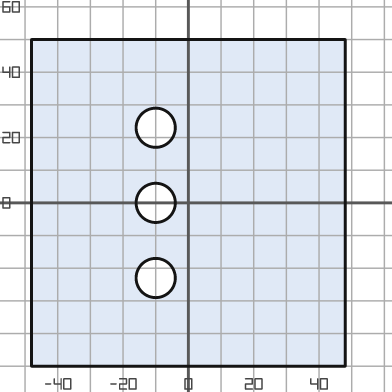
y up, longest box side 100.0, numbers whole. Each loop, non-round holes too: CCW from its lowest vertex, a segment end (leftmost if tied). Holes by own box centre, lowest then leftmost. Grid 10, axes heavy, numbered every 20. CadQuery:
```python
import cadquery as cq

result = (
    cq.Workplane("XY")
    .moveTo(-48.0, -50.0)
    .lineTo(48.0, -50.0)
    .lineTo(48.0, 50.0)
    .lineTo(-48.0, 50.0)
    .close()
    .moveTo(-10.0, -23.0)
    .circle(6.0)
    .moveTo(-10.0, 0.0)
    .circle(6.0)
    .moveTo(-10.0, 23.0)
    .circle(6.0)
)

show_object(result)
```